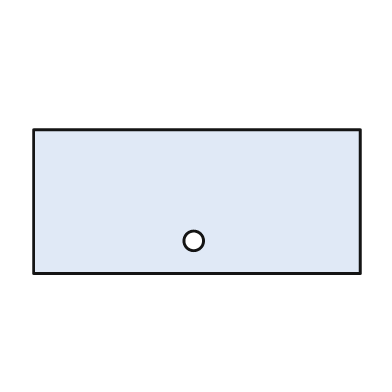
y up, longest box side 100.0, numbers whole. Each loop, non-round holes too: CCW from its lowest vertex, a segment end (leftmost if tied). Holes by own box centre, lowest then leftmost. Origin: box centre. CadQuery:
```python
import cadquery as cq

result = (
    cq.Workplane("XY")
    .moveTo(-50.0, -22.0)
    .lineTo(50.0, -22.0)
    .lineTo(50.0, 22.0)
    .lineTo(-50.0, 22.0)
    .close()
    .moveTo(-1.0, -12.0)
    .circle(3.0)
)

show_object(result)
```